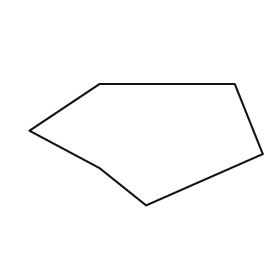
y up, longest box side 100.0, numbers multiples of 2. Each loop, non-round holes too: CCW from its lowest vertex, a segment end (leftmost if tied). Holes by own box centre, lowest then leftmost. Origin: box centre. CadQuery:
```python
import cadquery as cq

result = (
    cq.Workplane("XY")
    .moveTo(0.0, -26.0)
    .lineTo(50.0, -4.0)
    .lineTo(38.0, 26.0)
    .lineTo(-20.0, 26.0)
    .lineTo(-50.0, 6.0)
    .lineTo(-20.0, -10.0)
    .close()
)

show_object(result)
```